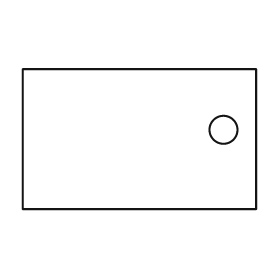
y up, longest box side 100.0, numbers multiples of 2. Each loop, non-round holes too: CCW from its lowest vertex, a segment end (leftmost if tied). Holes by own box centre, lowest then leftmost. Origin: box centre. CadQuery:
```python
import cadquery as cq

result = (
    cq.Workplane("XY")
    .moveTo(-50.0, -30.0)
    .lineTo(50.0, -30.0)
    .lineTo(50.0, 30.0)
    .lineTo(-50.0, 30.0)
    .close()
    .moveTo(36.0, 4.0)
    .circle(6.0)
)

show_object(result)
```